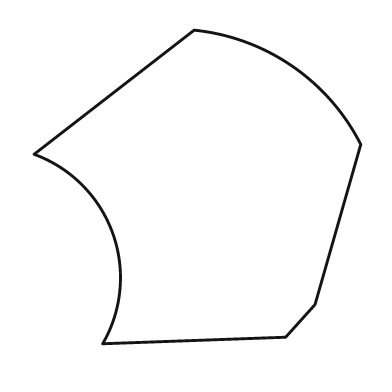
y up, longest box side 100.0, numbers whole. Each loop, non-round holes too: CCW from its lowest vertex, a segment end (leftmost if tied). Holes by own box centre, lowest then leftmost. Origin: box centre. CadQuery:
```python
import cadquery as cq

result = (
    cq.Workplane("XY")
    .moveTo(-29.0, -48.0)
    .lineTo(27.0, -46.0)
    .lineTo(36.0, -36.0)
    .lineTo(50.0, 13.0)
    .threePointArc((29.0, 37.0), (-1.0, 48.0))
    .lineTo(-50.0, 10.0)
    .threePointArc((-26.0, -14.0), (-29.0, -48.0))
    .close()
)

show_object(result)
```